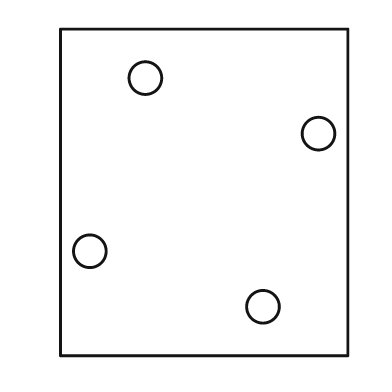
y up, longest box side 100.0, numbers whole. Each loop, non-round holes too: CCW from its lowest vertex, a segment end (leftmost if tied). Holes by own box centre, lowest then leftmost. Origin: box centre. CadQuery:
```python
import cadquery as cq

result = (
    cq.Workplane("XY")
    .moveTo(-44.0, -50.0)
    .lineTo(44.0, -50.0)
    .lineTo(44.0, 50.0)
    .lineTo(-44.0, 50.0)
    .close()
    .moveTo(18.0, -35.0)
    .circle(5.0)
    .moveTo(-35.0, -18.0)
    .circle(5.0)
    .moveTo(35.0, 18.0)
    .circle(5.0)
    .moveTo(-18.0, 35.0)
    .circle(5.0)
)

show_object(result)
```